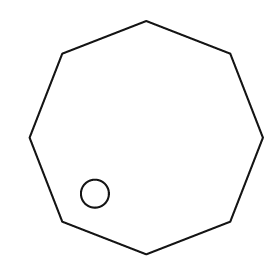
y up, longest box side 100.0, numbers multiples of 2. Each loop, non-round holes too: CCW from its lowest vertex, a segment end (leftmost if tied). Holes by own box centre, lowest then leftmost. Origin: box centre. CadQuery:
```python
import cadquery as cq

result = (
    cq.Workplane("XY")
    .moveTo(0.0, -50.0)
    .lineTo(36.0, -36.0)
    .lineTo(50.0, 0.0)
    .lineTo(36.0, 36.0)
    .lineTo(0.0, 50.0)
    .lineTo(-36.0, 36.0)
    .lineTo(-50.0, 0.0)
    .lineTo(-36.0, -36.0)
    .close()
    .moveTo(-22.0, -24.0)
    .circle(6.0)
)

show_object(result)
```